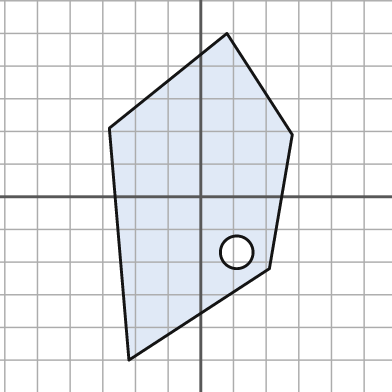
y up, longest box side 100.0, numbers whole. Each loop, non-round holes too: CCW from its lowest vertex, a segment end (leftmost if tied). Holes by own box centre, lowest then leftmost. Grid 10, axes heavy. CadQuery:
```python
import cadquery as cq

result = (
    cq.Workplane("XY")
    .moveTo(-22.0, -50.0)
    .lineTo(21.0, -22.0)
    .lineTo(28.0, 19.0)
    .lineTo(8.0, 50.0)
    .lineTo(-28.0, 21.0)
    .close()
    .moveTo(11.0, -17.0)
    .circle(5.0)
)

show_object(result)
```